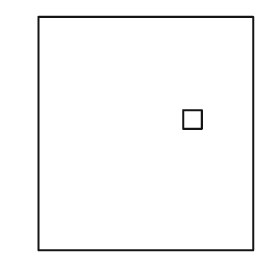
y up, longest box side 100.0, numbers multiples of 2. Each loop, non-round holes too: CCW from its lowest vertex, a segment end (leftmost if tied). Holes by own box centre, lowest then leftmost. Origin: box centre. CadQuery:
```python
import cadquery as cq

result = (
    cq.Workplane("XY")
    .moveTo(-46.0, -50.0)
    .lineTo(46.0, -50.0)
    .lineTo(46.0, 50.0)
    .lineTo(-46.0, 50.0)
    .close()
    .moveTo(16.0, 2.0)
    .lineTo(24.0, 2.0)
    .lineTo(24.0, 10.0)
    .lineTo(16.0, 10.0)
    .close()
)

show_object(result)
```